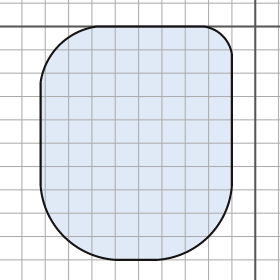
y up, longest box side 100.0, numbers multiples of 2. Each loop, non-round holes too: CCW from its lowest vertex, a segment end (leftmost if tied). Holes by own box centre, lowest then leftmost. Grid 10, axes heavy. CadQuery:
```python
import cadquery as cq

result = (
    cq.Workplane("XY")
    .moveTo(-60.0, -100.0)
    .lineTo(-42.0, -100.0)
    .threePointArc((-20.0, -90.0), (-10.0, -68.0))
    .lineTo(-10.0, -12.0)
    .threePointArc((-14.0, -4.0), (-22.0, 0.0))
    .lineTo(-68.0, 0.0)
    .threePointArc((-84.0, -8.0), (-92.0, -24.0))
    .lineTo(-92.0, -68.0)
    .threePointArc((-82.0, -90.0), (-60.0, -100.0))
    .close()
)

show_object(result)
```